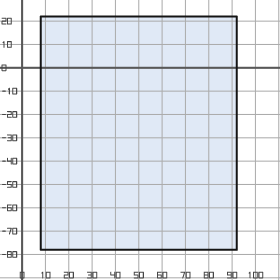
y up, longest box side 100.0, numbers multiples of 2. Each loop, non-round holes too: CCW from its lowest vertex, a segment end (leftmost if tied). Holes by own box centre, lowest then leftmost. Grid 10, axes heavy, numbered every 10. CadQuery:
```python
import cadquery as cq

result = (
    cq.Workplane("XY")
    .moveTo(8.0, -78.0)
    .lineTo(92.0, -78.0)
    .lineTo(92.0, 22.0)
    .lineTo(8.0, 22.0)
    .close()
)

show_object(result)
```